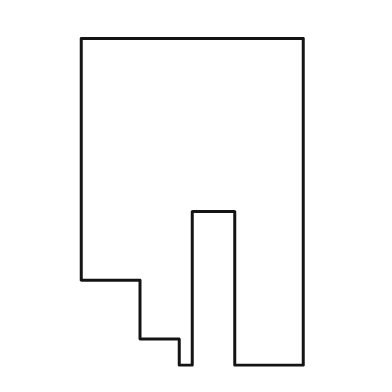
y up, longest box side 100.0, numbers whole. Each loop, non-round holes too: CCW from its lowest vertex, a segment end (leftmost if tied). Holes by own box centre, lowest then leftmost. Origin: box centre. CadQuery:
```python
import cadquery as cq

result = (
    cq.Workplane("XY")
    .moveTo(-4.0, -50.0)
    .lineTo(0.0, -50.0)
    .lineTo(0.0, -3.0)
    .lineTo(13.0, -3.0)
    .lineTo(13.0, -50.0)
    .lineTo(34.0, -50.0)
    .lineTo(34.0, 50.0)
    .lineTo(-34.0, 50.0)
    .lineTo(-34.0, -24.0)
    .lineTo(-16.0, -24.0)
    .lineTo(-16.0, -42.0)
    .lineTo(-4.0, -42.0)
    .close()
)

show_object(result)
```